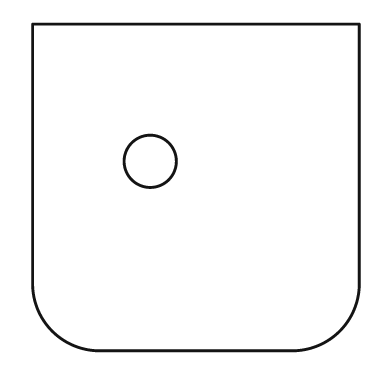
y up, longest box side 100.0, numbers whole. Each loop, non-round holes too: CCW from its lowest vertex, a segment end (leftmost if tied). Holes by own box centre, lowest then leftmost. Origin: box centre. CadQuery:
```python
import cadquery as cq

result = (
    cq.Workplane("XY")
    .moveTo(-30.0, -50.0)
    .lineTo(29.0, -50.0)
    .threePointArc((44.0, -44.0), (50.0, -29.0))
    .lineTo(50.0, 50.0)
    .lineTo(-50.0, 50.0)
    .lineTo(-50.0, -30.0)
    .threePointArc((-44.0, -44.0), (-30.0, -50.0))
    .close()
    .moveTo(-14.0, 8.0)
    .circle(8.0)
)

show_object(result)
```